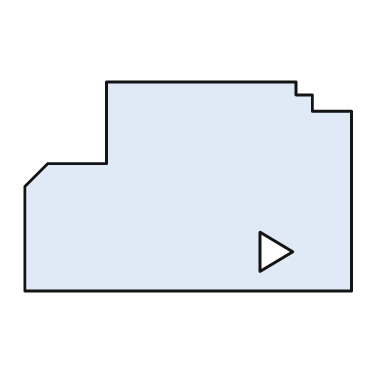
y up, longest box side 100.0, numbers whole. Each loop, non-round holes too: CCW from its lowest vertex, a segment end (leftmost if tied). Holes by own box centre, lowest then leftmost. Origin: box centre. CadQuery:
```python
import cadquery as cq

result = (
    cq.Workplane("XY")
    .moveTo(-50.0, -32.0)
    .lineTo(50.0, -32.0)
    .lineTo(50.0, 23.0)
    .lineTo(38.0, 23.0)
    .lineTo(38.0, 28.0)
    .lineTo(33.0, 28.0)
    .lineTo(33.0, 32.0)
    .lineTo(-25.0, 32.0)
    .lineTo(-25.0, 7.0)
    .lineTo(-43.0, 7.0)
    .lineTo(-50.0, 0.0)
    .close()
    .moveTo(22.0, -26.0)
    .lineTo(32.0, -20.0)
    .lineTo(22.0, -14.0)
    .close()
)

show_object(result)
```